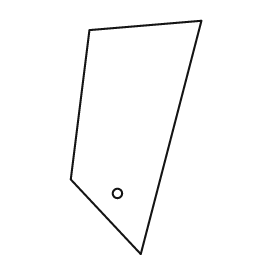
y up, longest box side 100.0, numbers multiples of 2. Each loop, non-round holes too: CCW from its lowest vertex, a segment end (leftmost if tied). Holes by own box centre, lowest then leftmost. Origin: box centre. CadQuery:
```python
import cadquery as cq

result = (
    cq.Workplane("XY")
    .moveTo(2.0, -50.0)
    .lineTo(28.0, 50.0)
    .lineTo(-20.0, 46.0)
    .lineTo(-28.0, -18.0)
    .close()
    .moveTo(-8.0, -24.0)
    .circle(2.0)
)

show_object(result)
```